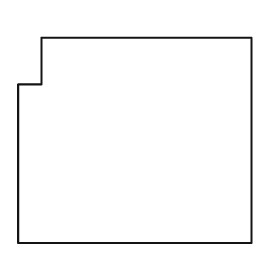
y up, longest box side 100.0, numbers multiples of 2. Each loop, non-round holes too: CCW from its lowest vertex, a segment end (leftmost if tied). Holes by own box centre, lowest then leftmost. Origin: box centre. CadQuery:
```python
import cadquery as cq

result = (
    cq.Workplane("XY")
    .moveTo(-50.0, -44.0)
    .lineTo(50.0, -44.0)
    .lineTo(50.0, 44.0)
    .lineTo(-40.0, 44.0)
    .lineTo(-40.0, 24.0)
    .lineTo(-50.0, 24.0)
    .close()
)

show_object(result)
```